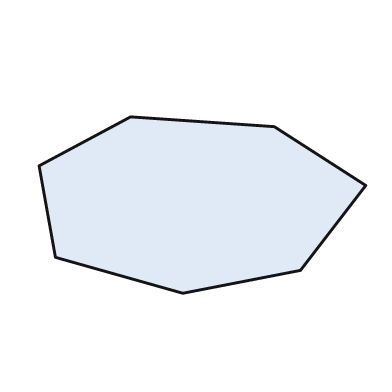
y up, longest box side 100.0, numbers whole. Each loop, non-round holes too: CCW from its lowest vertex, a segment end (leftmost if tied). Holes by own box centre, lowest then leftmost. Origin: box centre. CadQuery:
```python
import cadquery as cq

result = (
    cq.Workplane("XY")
    .moveTo(-6.0, -27.0)
    .lineTo(30.0, -20.0)
    .lineTo(50.0, 6.0)
    .lineTo(22.0, 24.0)
    .lineTo(-22.0, 27.0)
    .lineTo(-50.0, 12.0)
    .lineTo(-45.0, -16.0)
    .close()
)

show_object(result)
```